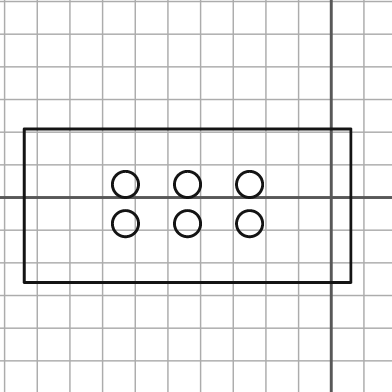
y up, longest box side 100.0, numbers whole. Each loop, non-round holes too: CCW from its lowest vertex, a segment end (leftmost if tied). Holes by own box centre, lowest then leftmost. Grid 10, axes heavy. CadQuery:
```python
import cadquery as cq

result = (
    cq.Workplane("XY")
    .moveTo(-94.0, -26.0)
    .lineTo(6.0, -26.0)
    .lineTo(6.0, 21.0)
    .lineTo(-94.0, 21.0)
    .close()
    .moveTo(-63.0, -8.0)
    .circle(4.0)
    .moveTo(-44.0, -8.0)
    .circle(4.0)
    .moveTo(-25.0, -8.0)
    .circle(4.0)
    .moveTo(-63.0, 4.0)
    .circle(4.0)
    .moveTo(-44.0, 4.0)
    .circle(4.0)
    .moveTo(-25.0, 4.0)
    .circle(4.0)
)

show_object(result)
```